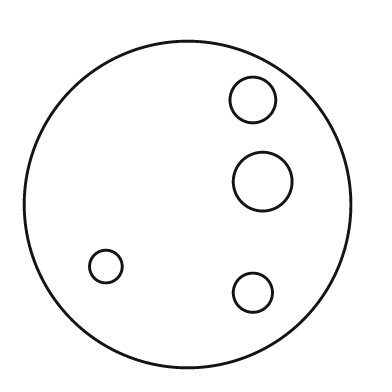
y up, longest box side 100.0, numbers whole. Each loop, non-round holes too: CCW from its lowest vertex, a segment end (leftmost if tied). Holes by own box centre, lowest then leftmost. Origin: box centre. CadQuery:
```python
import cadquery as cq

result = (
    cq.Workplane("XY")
    .moveTo(0.0, 0.0)
    .circle(50.0)
    .moveTo(20.0, -27.0)
    .circle(6.0)
    .moveTo(-25.0, -19.0)
    .circle(5.0)
    .moveTo(23.0, 7.0)
    .circle(9.0)
    .moveTo(20.0, 32.0)
    .circle(7.0)
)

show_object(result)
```